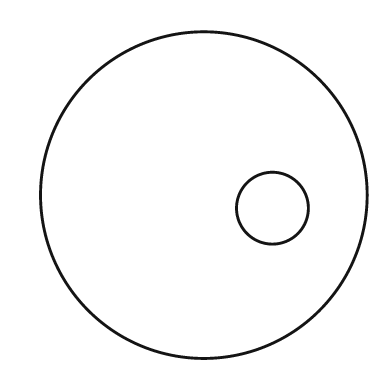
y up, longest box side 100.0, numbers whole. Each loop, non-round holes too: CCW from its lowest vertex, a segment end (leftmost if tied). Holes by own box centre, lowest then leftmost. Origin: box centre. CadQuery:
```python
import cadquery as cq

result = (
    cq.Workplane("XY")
    .moveTo(0.0, 0.0)
    .circle(50.0)
    .moveTo(21.0, -4.0)
    .circle(11.0)
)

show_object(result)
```